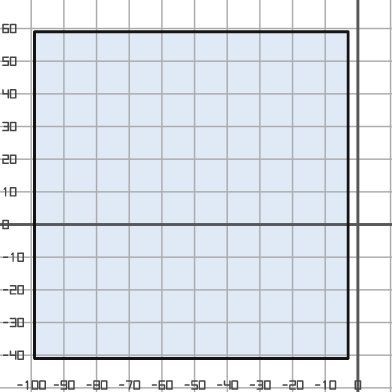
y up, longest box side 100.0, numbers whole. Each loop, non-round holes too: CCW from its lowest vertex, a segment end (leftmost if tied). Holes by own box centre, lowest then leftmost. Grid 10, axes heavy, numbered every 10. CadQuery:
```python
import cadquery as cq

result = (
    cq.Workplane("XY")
    .moveTo(-99.0, -41.0)
    .lineTo(-3.0, -41.0)
    .lineTo(-3.0, 59.0)
    .lineTo(-99.0, 59.0)
    .close()
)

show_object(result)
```